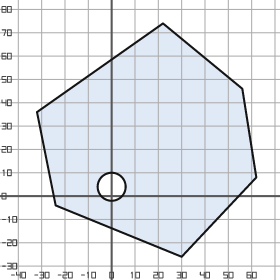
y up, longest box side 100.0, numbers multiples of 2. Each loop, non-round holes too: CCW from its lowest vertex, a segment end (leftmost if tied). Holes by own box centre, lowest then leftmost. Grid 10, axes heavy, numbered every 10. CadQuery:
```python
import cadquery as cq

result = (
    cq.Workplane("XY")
    .moveTo(30.0, -26.0)
    .lineTo(62.0, 8.0)
    .lineTo(56.0, 46.0)
    .lineTo(22.0, 74.0)
    .lineTo(-32.0, 36.0)
    .lineTo(-24.0, -4.0)
    .close()
    .moveTo(0.0, 4.0)
    .circle(6.0)
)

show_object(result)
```